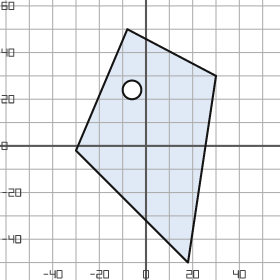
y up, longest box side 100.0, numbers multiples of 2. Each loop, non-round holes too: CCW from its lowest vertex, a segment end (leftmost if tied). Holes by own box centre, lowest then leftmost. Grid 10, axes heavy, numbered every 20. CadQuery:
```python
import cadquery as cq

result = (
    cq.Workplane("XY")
    .moveTo(18.0, -50.0)
    .lineTo(30.0, 30.0)
    .lineTo(-8.0, 50.0)
    .lineTo(-30.0, -2.0)
    .close()
    .moveTo(-6.0, 24.0)
    .circle(4.0)
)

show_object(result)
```